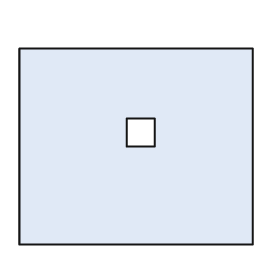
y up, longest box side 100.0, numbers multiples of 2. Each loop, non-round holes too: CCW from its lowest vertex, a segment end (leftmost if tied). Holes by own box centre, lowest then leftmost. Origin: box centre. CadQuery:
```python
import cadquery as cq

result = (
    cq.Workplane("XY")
    .moveTo(-50.0, -42.0)
    .lineTo(50.0, -42.0)
    .lineTo(50.0, 42.0)
    .lineTo(-50.0, 42.0)
    .close()
    .moveTo(-4.0, 0.0)
    .lineTo(8.0, 0.0)
    .lineTo(8.0, 12.0)
    .lineTo(-4.0, 12.0)
    .close()
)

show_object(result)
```